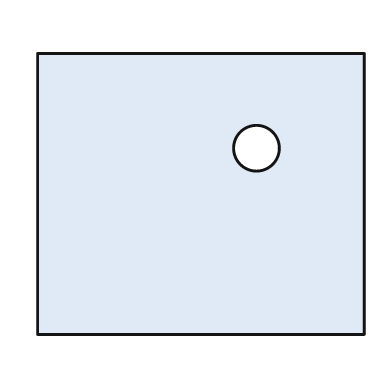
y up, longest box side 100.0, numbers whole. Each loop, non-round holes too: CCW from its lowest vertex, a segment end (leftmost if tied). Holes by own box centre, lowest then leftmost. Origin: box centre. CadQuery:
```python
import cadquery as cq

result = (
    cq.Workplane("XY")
    .moveTo(-50.0, -43.0)
    .lineTo(50.0, -43.0)
    .lineTo(50.0, 43.0)
    .lineTo(-50.0, 43.0)
    .close()
    .moveTo(17.0, 14.0)
    .circle(7.0)
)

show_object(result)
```